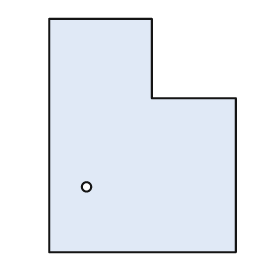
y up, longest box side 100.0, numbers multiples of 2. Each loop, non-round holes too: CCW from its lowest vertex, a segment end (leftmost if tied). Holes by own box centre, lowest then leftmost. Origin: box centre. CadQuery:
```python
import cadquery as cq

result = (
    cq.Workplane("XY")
    .moveTo(-40.0, -50.0)
    .lineTo(40.0, -50.0)
    .lineTo(40.0, 16.0)
    .lineTo(4.0, 16.0)
    .lineTo(4.0, 50.0)
    .lineTo(-40.0, 50.0)
    .close()
    .moveTo(-24.0, -22.0)
    .circle(2.0)
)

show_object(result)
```